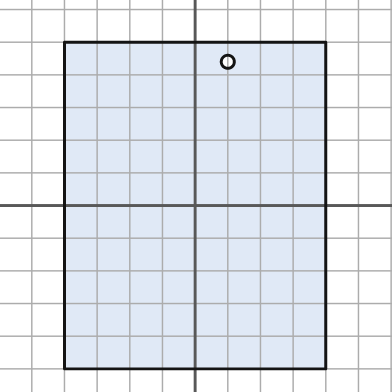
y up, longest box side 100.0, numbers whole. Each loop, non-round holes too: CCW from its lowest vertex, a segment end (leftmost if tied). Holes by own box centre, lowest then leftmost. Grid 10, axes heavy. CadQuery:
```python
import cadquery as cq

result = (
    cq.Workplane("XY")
    .moveTo(-40.0, -50.0)
    .lineTo(40.0, -50.0)
    .lineTo(40.0, 50.0)
    .lineTo(-40.0, 50.0)
    .close()
    .moveTo(10.0, 44.0)
    .circle(2.0)
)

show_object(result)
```